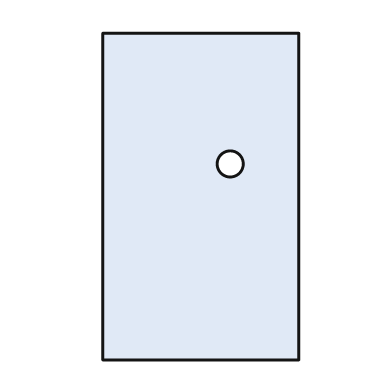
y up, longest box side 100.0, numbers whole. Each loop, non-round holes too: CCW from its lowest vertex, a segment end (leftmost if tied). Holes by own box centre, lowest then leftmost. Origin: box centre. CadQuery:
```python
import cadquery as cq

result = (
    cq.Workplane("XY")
    .moveTo(-30.0, -50.0)
    .lineTo(30.0, -50.0)
    .lineTo(30.0, 50.0)
    .lineTo(-30.0, 50.0)
    .close()
    .moveTo(9.0, 10.0)
    .circle(4.0)
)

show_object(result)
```